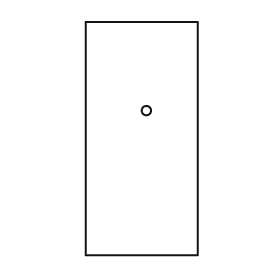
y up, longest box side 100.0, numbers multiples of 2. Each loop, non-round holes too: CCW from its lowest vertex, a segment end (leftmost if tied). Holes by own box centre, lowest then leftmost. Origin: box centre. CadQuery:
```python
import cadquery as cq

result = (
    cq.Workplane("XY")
    .moveTo(-24.0, -50.0)
    .lineTo(24.0, -50.0)
    .lineTo(24.0, 50.0)
    .lineTo(-24.0, 50.0)
    .close()
    .moveTo(2.0, 12.0)
    .circle(2.0)
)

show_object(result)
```